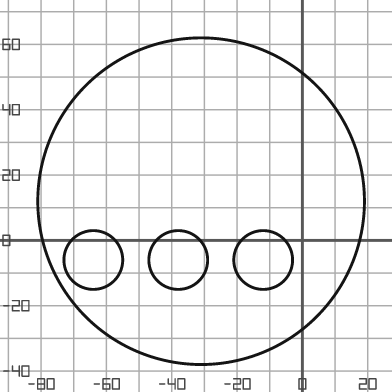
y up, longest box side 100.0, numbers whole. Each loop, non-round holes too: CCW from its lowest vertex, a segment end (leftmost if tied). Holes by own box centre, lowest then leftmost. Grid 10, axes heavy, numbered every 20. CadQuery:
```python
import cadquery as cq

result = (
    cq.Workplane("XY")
    .moveTo(-31.0, 12.0)
    .circle(50.0)
    .moveTo(-64.0, -6.0)
    .circle(9.0)
    .moveTo(-38.0, -6.0)
    .circle(9.0)
    .moveTo(-12.0, -6.0)
    .circle(9.0)
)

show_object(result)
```